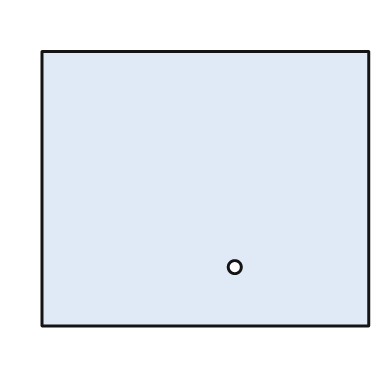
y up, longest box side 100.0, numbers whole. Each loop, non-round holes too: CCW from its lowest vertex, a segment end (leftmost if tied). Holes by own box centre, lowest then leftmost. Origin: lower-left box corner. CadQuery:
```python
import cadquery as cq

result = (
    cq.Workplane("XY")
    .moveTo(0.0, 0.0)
    .lineTo(100.0, 0.0)
    .lineTo(100.0, 84.0)
    .lineTo(0.0, 84.0)
    .close()
    .moveTo(59.0, 18.0)
    .circle(2.0)
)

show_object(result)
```